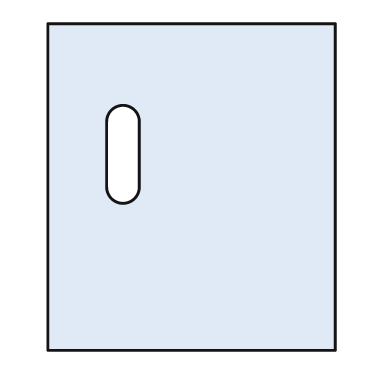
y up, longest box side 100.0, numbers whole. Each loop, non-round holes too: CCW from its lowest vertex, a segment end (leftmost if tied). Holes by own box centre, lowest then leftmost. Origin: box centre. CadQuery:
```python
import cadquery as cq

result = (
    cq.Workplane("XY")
    .moveTo(-44.0, -50.0)
    .lineTo(44.0, -50.0)
    .lineTo(44.0, 50.0)
    .lineTo(-44.0, 50.0)
    .close()
    .moveTo(-26.0, 0.0)
    .threePointArc((-21.0, -5.0), (-16.0, 0.0))
    .lineTo(-16.0, 20.0)
    .threePointArc((-21.0, 25.0), (-26.0, 20.0))
    .close()
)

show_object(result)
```